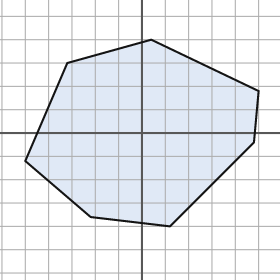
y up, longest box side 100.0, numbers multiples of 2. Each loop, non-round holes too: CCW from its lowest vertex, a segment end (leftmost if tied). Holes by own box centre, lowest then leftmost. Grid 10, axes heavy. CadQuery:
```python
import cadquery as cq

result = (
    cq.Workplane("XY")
    .moveTo(12.0, -40.0)
    .lineTo(48.0, -4.0)
    .lineTo(50.0, 18.0)
    .lineTo(4.0, 40.0)
    .lineTo(-32.0, 30.0)
    .lineTo(-50.0, -12.0)
    .lineTo(-22.0, -36.0)
    .close()
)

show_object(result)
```